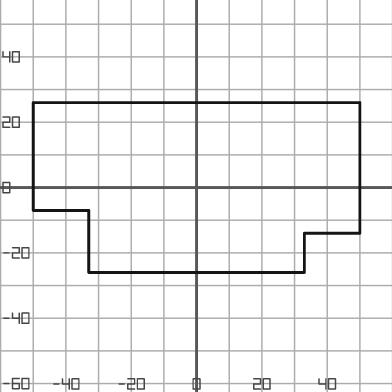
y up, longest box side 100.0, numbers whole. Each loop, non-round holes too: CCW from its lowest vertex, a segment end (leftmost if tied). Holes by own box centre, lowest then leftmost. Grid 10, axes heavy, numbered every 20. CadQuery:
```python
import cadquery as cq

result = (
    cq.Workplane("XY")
    .moveTo(-33.0, -26.0)
    .lineTo(33.0, -26.0)
    .lineTo(33.0, -14.0)
    .lineTo(50.0, -14.0)
    .lineTo(50.0, 26.0)
    .lineTo(-50.0, 26.0)
    .lineTo(-50.0, -7.0)
    .lineTo(-33.0, -7.0)
    .close()
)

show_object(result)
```